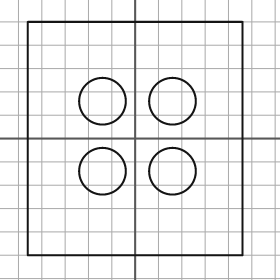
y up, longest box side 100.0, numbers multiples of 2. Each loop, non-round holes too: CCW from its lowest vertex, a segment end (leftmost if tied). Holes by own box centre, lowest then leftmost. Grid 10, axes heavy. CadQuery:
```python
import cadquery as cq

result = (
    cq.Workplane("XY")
    .moveTo(-46.0, -50.0)
    .lineTo(46.0, -50.0)
    .lineTo(46.0, 50.0)
    .lineTo(-46.0, 50.0)
    .close()
    .moveTo(-14.0, -14.0)
    .circle(10.0)
    .moveTo(16.0, -14.0)
    .circle(10.0)
    .moveTo(-14.0, 16.0)
    .circle(10.0)
    .moveTo(16.0, 16.0)
    .circle(10.0)
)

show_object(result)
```